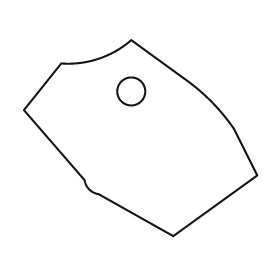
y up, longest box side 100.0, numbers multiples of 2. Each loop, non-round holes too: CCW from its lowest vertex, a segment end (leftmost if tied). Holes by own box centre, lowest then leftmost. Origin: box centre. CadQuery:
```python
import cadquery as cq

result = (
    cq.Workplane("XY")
    .moveTo(14.0, -42.0)
    .lineTo(50.0, -16.0)
    .lineTo(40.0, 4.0)
    .threePointArc((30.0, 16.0), (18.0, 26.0))
    .lineTo(-4.0, 42.0)
    .threePointArc((-18.0, 34.0), (-34.0, 32.0))
    .lineTo(-50.0, 12.0)
    .lineTo(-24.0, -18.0)
    .threePointArc((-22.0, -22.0), (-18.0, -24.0))
    .close()
    .moveTo(-4.0, 20.0)
    .circle(6.0)
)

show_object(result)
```